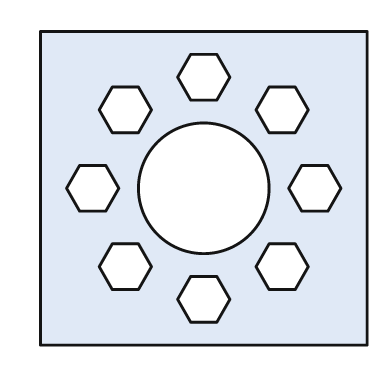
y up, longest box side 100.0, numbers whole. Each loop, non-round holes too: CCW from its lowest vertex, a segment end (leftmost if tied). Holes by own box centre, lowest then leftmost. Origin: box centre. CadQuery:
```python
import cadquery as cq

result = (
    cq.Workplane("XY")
    .moveTo(-50.0, -48.0)
    .lineTo(50.0, -48.0)
    .lineTo(50.0, 48.0)
    .lineTo(-50.0, 48.0)
    .close()
    .moveTo(-4.0, -41.0)
    .lineTo(4.0, -41.0)
    .lineTo(8.0, -34.0)
    .lineTo(4.0, -27.0)
    .lineTo(-4.0, -27.0)
    .lineTo(-8.0, -34.0)
    .close()
    .moveTo(-28.0, -31.0)
    .lineTo(-20.0, -31.0)
    .lineTo(-16.0, -24.0)
    .lineTo(-20.0, -17.0)
    .lineTo(-28.0, -17.0)
    .lineTo(-32.0, -24.0)
    .close()
    .moveTo(20.0, -31.0)
    .lineTo(28.0, -31.0)
    .lineTo(32.0, -24.0)
    .lineTo(28.0, -17.0)
    .lineTo(20.0, -17.0)
    .lineTo(16.0, -24.0)
    .close()
    .moveTo(-38.0, -7.0)
    .lineTo(-30.0, -7.0)
    .lineTo(-26.0, 0.0)
    .lineTo(-30.0, 7.0)
    .lineTo(-38.0, 7.0)
    .lineTo(-42.0, 0.0)
    .close()
    .moveTo(0.0, 0.0)
    .circle(20.0)
    .moveTo(30.0, -7.0)
    .lineTo(38.0, -7.0)
    .lineTo(42.0, 0.0)
    .lineTo(38.0, 7.0)
    .lineTo(30.0, 7.0)
    .lineTo(26.0, 0.0)
    .close()
    .moveTo(-28.0, 17.0)
    .lineTo(-20.0, 17.0)
    .lineTo(-16.0, 24.0)
    .lineTo(-20.0, 31.0)
    .lineTo(-28.0, 31.0)
    .lineTo(-32.0, 24.0)
    .close()
    .moveTo(20.0, 17.0)
    .lineTo(28.0, 17.0)
    .lineTo(32.0, 24.0)
    .lineTo(28.0, 31.0)
    .lineTo(20.0, 31.0)
    .lineTo(16.0, 24.0)
    .close()
    .moveTo(-4.0, 27.0)
    .lineTo(4.0, 27.0)
    .lineTo(8.0, 34.0)
    .lineTo(4.0, 41.0)
    .lineTo(-4.0, 41.0)
    .lineTo(-8.0, 34.0)
    .close()
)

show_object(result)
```